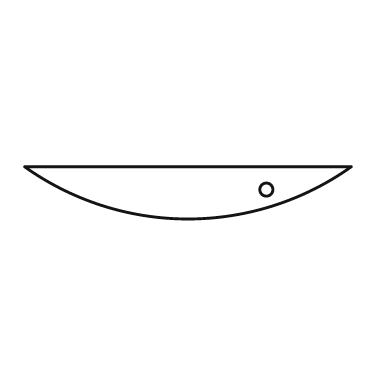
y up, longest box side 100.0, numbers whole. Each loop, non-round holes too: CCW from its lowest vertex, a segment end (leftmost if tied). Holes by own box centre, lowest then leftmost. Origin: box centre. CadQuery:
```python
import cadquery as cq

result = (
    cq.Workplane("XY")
    .moveTo(-50.0, 8.0)
    .threePointArc((0.0, -8.0), (50.0, 8.0))
    .close()
    .moveTo(24.0, 1.0)
    .circle(2.0)
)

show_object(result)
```